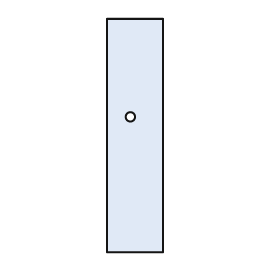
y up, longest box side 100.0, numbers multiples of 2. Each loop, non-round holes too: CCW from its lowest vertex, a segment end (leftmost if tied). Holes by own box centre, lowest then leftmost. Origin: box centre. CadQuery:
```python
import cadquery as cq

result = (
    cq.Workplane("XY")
    .moveTo(-12.0, -50.0)
    .lineTo(12.0, -50.0)
    .lineTo(12.0, 50.0)
    .lineTo(-12.0, 50.0)
    .close()
    .moveTo(-2.0, 8.0)
    .circle(2.0)
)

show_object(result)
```